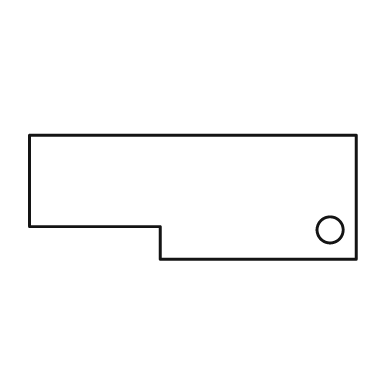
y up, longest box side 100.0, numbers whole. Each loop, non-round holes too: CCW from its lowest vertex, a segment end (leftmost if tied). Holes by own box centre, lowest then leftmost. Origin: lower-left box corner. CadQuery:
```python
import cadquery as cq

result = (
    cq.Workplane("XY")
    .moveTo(40.0, 0.0)
    .lineTo(100.0, 0.0)
    .lineTo(100.0, 38.0)
    .lineTo(0.0, 38.0)
    .lineTo(0.0, 10.0)
    .lineTo(40.0, 10.0)
    .close()
    .moveTo(92.0, 9.0)
    .circle(4.0)
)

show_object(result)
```